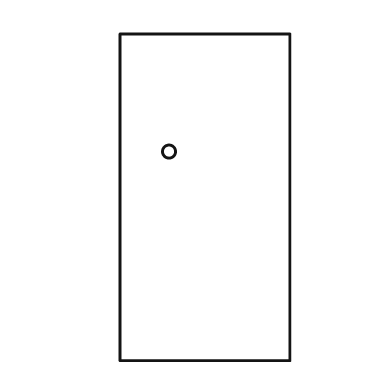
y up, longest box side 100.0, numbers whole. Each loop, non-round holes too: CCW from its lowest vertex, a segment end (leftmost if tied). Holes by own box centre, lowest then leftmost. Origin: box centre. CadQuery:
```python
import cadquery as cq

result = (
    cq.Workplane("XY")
    .moveTo(-26.0, -50.0)
    .lineTo(26.0, -50.0)
    .lineTo(26.0, 50.0)
    .lineTo(-26.0, 50.0)
    .close()
    .moveTo(-11.0, 14.0)
    .circle(2.0)
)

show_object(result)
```